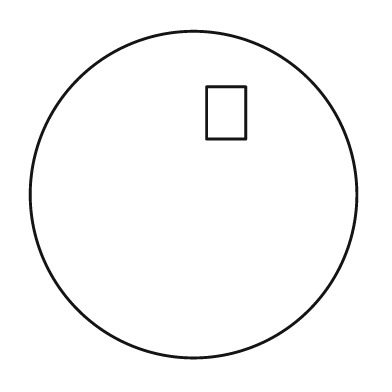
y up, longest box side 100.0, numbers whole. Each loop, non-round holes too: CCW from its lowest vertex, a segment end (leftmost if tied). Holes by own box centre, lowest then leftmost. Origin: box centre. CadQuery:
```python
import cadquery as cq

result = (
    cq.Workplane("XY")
    .moveTo(0.0, 0.0)
    .circle(50.0)
    .moveTo(4.0, 17.0)
    .lineTo(16.0, 17.0)
    .lineTo(16.0, 33.0)
    .lineTo(4.0, 33.0)
    .close()
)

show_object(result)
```